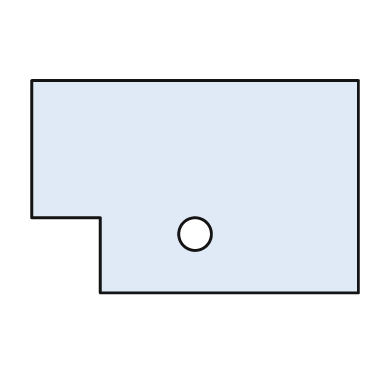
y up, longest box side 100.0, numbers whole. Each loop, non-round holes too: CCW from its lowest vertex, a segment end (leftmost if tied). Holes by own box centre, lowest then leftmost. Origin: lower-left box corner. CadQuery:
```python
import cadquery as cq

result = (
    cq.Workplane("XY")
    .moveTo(21.0, 0.0)
    .lineTo(100.0, 0.0)
    .lineTo(100.0, 65.0)
    .lineTo(0.0, 65.0)
    .lineTo(0.0, 23.0)
    .lineTo(21.0, 23.0)
    .close()
    .moveTo(50.0, 18.0)
    .circle(5.0)
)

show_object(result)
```